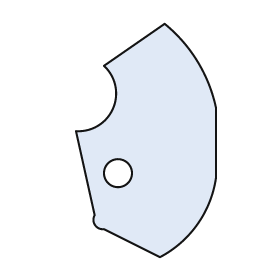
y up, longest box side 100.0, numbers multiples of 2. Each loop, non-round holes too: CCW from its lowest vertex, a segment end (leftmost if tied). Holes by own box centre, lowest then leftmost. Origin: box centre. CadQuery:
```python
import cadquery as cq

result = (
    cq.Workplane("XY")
    .moveTo(6.0, -50.0)
    .threePointArc((22.0, -36.0), (30.0, -16.0))
    .lineTo(30.0, 14.0)
    .threePointArc((22.0, 34.0), (8.0, 50.0))
    .lineTo(-18.0, 32.0)
    .threePointArc((-14.0, 14.0), (-30.0, 4.0))
    .lineTo(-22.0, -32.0)
    .threePointArc((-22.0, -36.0), (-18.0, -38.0))
    .close()
    .moveTo(-12.0, -14.0)
    .circle(6.0)
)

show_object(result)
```